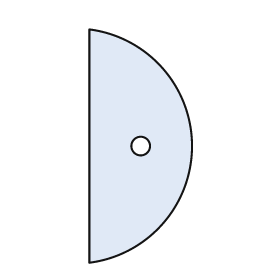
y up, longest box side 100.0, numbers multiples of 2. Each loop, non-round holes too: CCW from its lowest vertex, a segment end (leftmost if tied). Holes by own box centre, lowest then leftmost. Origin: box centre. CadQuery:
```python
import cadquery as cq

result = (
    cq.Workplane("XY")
    .moveTo(-22.0, -50.0)
    .threePointArc((22.0, 0.0), (-22.0, 50.0))
    .close()
    .moveTo(0.0, 0.0)
    .circle(4.0)
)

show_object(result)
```